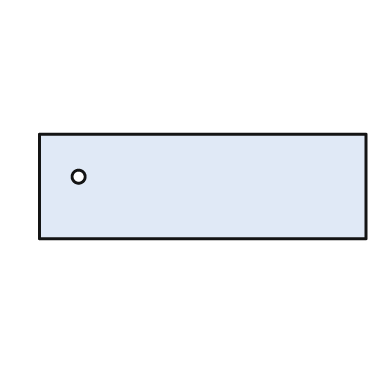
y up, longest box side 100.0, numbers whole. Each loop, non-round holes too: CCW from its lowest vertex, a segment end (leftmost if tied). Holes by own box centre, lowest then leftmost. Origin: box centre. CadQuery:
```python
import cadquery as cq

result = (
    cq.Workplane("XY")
    .moveTo(-50.0, -16.0)
    .lineTo(50.0, -16.0)
    .lineTo(50.0, 16.0)
    .lineTo(-50.0, 16.0)
    .close()
    .moveTo(-38.0, 3.0)
    .circle(2.0)
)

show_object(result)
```